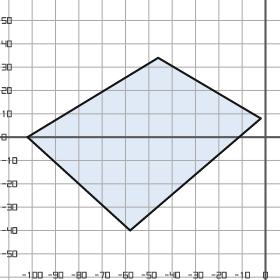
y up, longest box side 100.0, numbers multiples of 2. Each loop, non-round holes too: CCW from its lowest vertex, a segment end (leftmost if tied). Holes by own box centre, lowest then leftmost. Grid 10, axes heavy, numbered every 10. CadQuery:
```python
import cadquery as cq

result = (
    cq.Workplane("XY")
    .moveTo(-58.0, -40.0)
    .lineTo(-2.0, 8.0)
    .lineTo(-46.0, 34.0)
    .lineTo(-102.0, 0.0)
    .close()
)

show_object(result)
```